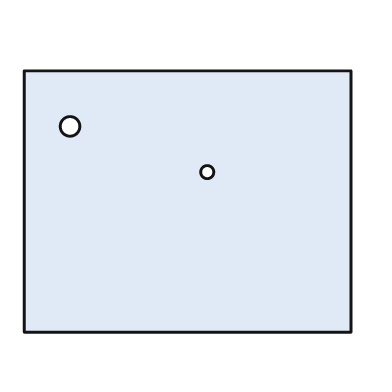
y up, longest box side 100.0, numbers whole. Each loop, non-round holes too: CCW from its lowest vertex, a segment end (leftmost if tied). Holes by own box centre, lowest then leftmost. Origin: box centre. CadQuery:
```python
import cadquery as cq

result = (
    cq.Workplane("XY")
    .moveTo(-50.0, -40.0)
    .lineTo(50.0, -40.0)
    .lineTo(50.0, 40.0)
    .lineTo(-50.0, 40.0)
    .close()
    .moveTo(6.0, 9.0)
    .circle(2.0)
    .moveTo(-36.0, 23.0)
    .circle(3.0)
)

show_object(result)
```